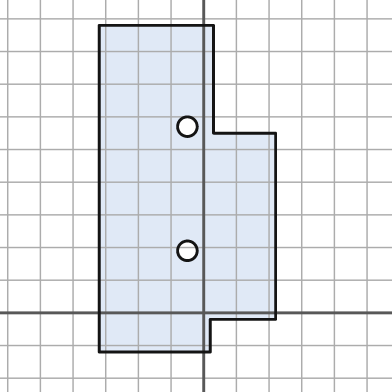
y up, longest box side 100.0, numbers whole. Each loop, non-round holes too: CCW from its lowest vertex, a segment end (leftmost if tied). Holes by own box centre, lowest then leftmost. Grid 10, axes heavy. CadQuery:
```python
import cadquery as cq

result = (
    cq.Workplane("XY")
    .moveTo(-32.0, -12.0)
    .lineTo(2.0, -12.0)
    .lineTo(2.0, -2.0)
    .lineTo(22.0, -2.0)
    .lineTo(22.0, 55.0)
    .lineTo(3.0, 55.0)
    .lineTo(3.0, 88.0)
    .lineTo(-32.0, 88.0)
    .close()
    .moveTo(-5.0, 19.0)
    .circle(3.0)
    .moveTo(-5.0, 57.0)
    .circle(3.0)
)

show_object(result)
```